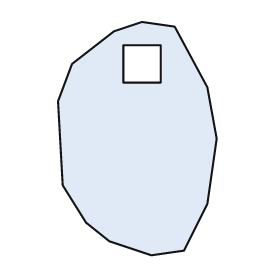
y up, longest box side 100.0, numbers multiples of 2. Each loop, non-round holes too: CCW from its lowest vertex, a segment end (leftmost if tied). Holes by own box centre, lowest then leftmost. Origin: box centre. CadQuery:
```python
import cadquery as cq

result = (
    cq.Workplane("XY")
    .moveTo(6.0, -50.0)
    .lineTo(20.0, -48.0)
    .lineTo(30.0, -28.0)
    .lineTo(34.0, 0.0)
    .lineTo(30.0, 22.0)
    .lineTo(16.0, 48.0)
    .lineTo(2.0, 50.0)
    .lineTo(-10.0, 46.0)
    .lineTo(-28.0, 32.0)
    .lineTo(-34.0, 16.0)
    .lineTo(-32.0, -20.0)
    .lineTo(-22.0, -36.0)
    .lineTo(-12.0, -44.0)
    .close()
    .moveTo(-6.0, 24.0)
    .lineTo(10.0, 24.0)
    .lineTo(10.0, 40.0)
    .lineTo(-6.0, 40.0)
    .close()
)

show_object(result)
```